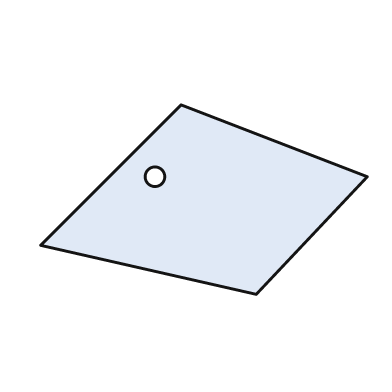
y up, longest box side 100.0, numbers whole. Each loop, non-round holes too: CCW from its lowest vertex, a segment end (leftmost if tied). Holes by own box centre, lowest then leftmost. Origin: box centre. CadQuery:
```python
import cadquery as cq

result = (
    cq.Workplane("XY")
    .moveTo(16.0, -29.0)
    .lineTo(50.0, 7.0)
    .lineTo(-7.0, 29.0)
    .lineTo(-50.0, -14.0)
    .close()
    .moveTo(-15.0, 7.0)
    .circle(3.0)
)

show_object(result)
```